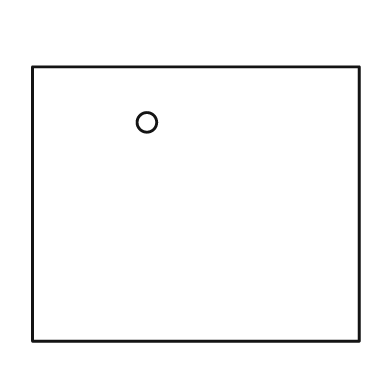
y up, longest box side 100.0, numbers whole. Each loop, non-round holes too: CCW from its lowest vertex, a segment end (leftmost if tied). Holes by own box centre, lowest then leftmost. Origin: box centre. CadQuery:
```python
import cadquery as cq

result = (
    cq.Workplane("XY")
    .moveTo(-50.0, -42.0)
    .lineTo(50.0, -42.0)
    .lineTo(50.0, 42.0)
    .lineTo(-50.0, 42.0)
    .close()
    .moveTo(-15.0, 25.0)
    .circle(3.0)
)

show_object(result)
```